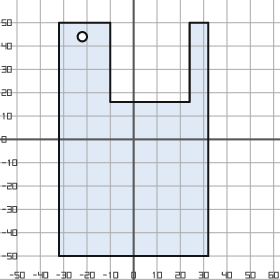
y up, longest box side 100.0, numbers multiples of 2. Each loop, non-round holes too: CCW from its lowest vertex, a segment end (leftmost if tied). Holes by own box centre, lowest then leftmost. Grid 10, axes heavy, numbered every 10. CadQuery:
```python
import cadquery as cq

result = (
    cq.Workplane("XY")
    .moveTo(-32.0, -50.0)
    .lineTo(32.0, -50.0)
    .lineTo(32.0, 50.0)
    .lineTo(24.0, 50.0)
    .lineTo(24.0, 16.0)
    .lineTo(-10.0, 16.0)
    .lineTo(-10.0, 50.0)
    .lineTo(-32.0, 50.0)
    .close()
    .moveTo(-22.0, 44.0)
    .circle(2.0)
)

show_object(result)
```